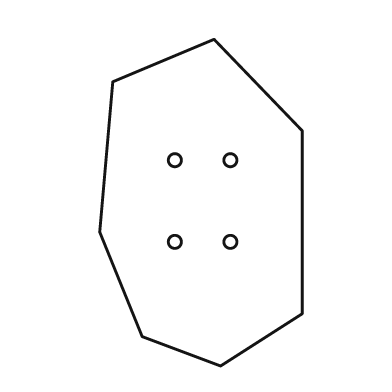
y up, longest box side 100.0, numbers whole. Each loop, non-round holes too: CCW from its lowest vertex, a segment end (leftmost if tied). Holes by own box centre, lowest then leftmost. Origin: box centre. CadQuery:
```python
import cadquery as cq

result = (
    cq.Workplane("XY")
    .moveTo(6.0, -50.0)
    .lineTo(31.0, -34.0)
    .lineTo(31.0, 22.0)
    .lineTo(4.0, 50.0)
    .lineTo(-27.0, 37.0)
    .lineTo(-31.0, -9.0)
    .lineTo(-18.0, -41.0)
    .close()
    .moveTo(-8.0, -12.0)
    .circle(2.0)
    .moveTo(9.0, -12.0)
    .circle(2.0)
    .moveTo(-8.0, 13.0)
    .circle(2.0)
    .moveTo(9.0, 13.0)
    .circle(2.0)
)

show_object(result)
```